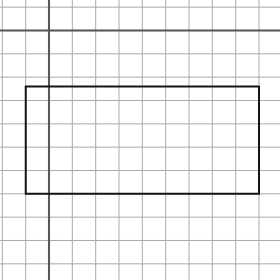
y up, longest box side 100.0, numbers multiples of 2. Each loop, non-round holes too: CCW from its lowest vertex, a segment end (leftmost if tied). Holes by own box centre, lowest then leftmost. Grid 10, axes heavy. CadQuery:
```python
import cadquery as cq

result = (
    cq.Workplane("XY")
    .moveTo(-10.0, -70.0)
    .lineTo(90.0, -70.0)
    .lineTo(90.0, -24.0)
    .lineTo(-10.0, -24.0)
    .close()
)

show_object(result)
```